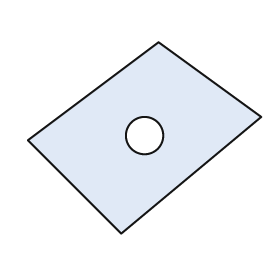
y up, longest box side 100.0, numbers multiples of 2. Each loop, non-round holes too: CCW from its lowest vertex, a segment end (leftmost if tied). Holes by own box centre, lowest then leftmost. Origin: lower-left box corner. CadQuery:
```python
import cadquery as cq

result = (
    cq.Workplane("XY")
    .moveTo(40.0, 0.0)
    .lineTo(100.0, 50.0)
    .lineTo(56.0, 82.0)
    .lineTo(0.0, 40.0)
    .close()
    .moveTo(50.0, 42.0)
    .circle(8.0)
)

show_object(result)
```